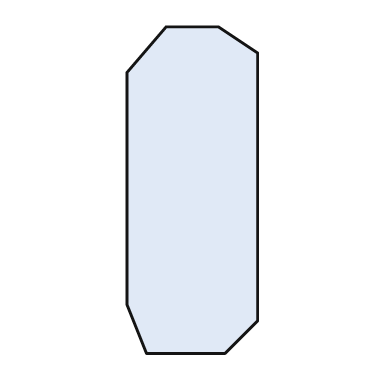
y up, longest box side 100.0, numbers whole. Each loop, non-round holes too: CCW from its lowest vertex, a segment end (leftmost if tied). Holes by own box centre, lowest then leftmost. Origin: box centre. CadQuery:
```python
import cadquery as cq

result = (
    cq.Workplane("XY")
    .moveTo(-14.0, -50.0)
    .lineTo(10.0, -50.0)
    .lineTo(20.0, -40.0)
    .lineTo(20.0, 42.0)
    .lineTo(8.0, 50.0)
    .lineTo(-8.0, 50.0)
    .lineTo(-20.0, 36.0)
    .lineTo(-20.0, -35.0)
    .close()
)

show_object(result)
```